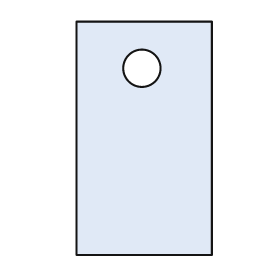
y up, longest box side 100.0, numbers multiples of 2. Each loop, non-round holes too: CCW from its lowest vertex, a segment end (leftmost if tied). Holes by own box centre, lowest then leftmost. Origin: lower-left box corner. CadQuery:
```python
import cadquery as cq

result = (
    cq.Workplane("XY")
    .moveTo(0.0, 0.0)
    .lineTo(58.0, 0.0)
    .lineTo(58.0, 100.0)
    .lineTo(0.0, 100.0)
    .close()
    .moveTo(28.0, 80.0)
    .circle(8.0)
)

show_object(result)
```